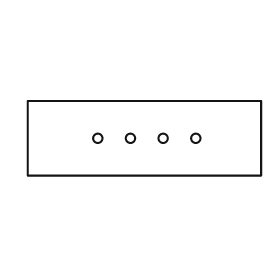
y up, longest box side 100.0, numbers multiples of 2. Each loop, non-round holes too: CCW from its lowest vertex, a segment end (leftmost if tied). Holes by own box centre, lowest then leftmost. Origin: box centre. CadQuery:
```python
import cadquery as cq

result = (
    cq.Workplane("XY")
    .moveTo(-50.0, -16.0)
    .lineTo(50.0, -16.0)
    .lineTo(50.0, 16.0)
    .lineTo(-50.0, 16.0)
    .close()
    .moveTo(-20.0, 0.0)
    .circle(2.0)
    .moveTo(-6.0, 0.0)
    .circle(2.0)
    .moveTo(8.0, 0.0)
    .circle(2.0)
    .moveTo(22.0, 0.0)
    .circle(2.0)
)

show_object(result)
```